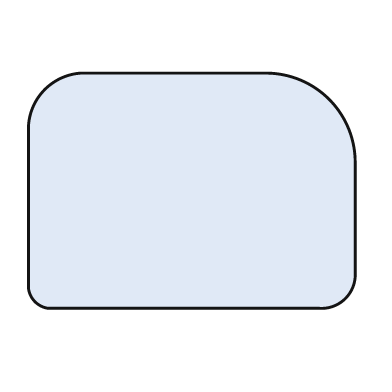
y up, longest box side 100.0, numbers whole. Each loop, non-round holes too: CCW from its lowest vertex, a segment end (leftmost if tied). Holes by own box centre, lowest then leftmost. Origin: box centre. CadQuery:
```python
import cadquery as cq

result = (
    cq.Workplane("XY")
    .moveTo(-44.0, -36.0)
    .lineTo(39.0, -36.0)
    .threePointArc((47.0, -33.0), (50.0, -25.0))
    .lineTo(50.0, 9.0)
    .threePointArc((42.0, 28.0), (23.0, 36.0))
    .lineTo(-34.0, 36.0)
    .threePointArc((-45.0, 31.0), (-50.0, 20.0))
    .lineTo(-50.0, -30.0)
    .threePointArc((-48.0, -34.0), (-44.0, -36.0))
    .close()
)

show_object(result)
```